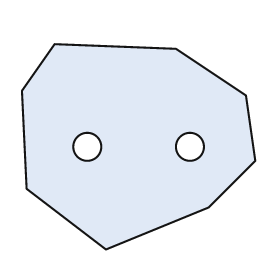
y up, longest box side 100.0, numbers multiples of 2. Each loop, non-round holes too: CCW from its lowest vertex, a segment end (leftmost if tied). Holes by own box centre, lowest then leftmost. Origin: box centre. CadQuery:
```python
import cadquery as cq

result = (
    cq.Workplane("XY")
    .moveTo(-14.0, -44.0)
    .lineTo(30.0, -26.0)
    .lineTo(50.0, -6.0)
    .lineTo(46.0, 22.0)
    .lineTo(16.0, 42.0)
    .lineTo(-36.0, 44.0)
    .lineTo(-50.0, 24.0)
    .lineTo(-48.0, -18.0)
    .close()
    .moveTo(-22.0, 0.0)
    .circle(6.0)
    .moveTo(22.0, 0.0)
    .circle(6.0)
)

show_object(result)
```